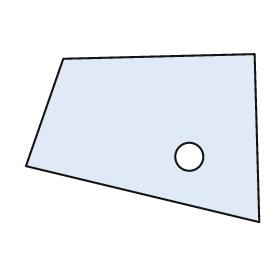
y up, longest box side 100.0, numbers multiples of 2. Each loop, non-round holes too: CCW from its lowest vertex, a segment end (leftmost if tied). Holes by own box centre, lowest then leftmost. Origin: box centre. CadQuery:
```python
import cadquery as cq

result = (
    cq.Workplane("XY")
    .moveTo(50.0, -36.0)
    .lineTo(48.0, 36.0)
    .lineTo(-34.0, 34.0)
    .lineTo(-50.0, -12.0)
    .close()
    .moveTo(20.0, -8.0)
    .circle(6.0)
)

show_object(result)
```